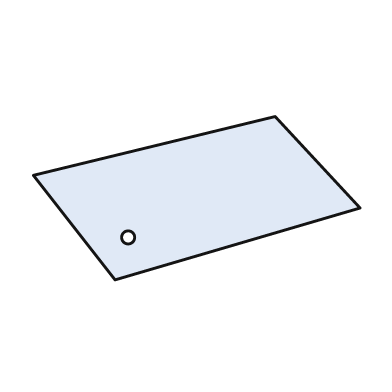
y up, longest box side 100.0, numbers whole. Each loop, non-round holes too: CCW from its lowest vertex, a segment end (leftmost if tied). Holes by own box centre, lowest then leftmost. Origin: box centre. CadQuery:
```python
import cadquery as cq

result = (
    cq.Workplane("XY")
    .moveTo(-25.0, -25.0)
    .lineTo(50.0, -3.0)
    .lineTo(24.0, 25.0)
    .lineTo(-50.0, 7.0)
    .close()
    .moveTo(-21.0, -12.0)
    .circle(2.0)
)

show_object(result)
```